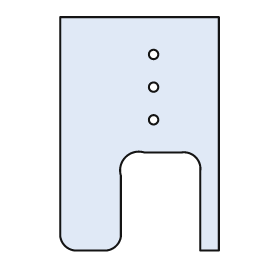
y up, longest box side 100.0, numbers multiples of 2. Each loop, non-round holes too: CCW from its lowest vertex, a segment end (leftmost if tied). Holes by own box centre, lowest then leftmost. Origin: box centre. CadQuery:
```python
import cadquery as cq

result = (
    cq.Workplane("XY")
    .moveTo(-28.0, -50.0)
    .lineTo(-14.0, -50.0)
    .threePointArc((-10.0, -48.0), (-8.0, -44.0))
    .lineTo(-8.0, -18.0)
    .threePointArc((-6.0, -10.0), (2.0, -8.0))
    .lineTo(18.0, -8.0)
    .threePointArc((24.0, -10.0), (26.0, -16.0))
    .lineTo(26.0, -50.0)
    .lineTo(34.0, -50.0)
    .lineTo(34.0, 50.0)
    .lineTo(-34.0, 50.0)
    .lineTo(-34.0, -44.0)
    .threePointArc((-32.0, -48.0), (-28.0, -50.0))
    .close()
    .moveTo(6.0, 6.0)
    .circle(2.0)
    .moveTo(6.0, 20.0)
    .circle(2.0)
    .moveTo(6.0, 34.0)
    .circle(2.0)
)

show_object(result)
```